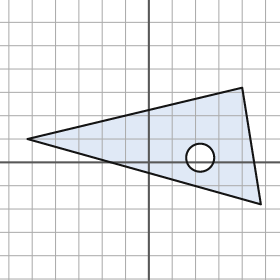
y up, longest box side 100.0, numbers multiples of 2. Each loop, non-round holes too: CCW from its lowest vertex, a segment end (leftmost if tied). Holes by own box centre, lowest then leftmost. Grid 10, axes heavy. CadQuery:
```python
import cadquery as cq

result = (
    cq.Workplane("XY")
    .moveTo(48.0, -18.0)
    .lineTo(40.0, 32.0)
    .lineTo(-52.0, 10.0)
    .close()
    .moveTo(22.0, 2.0)
    .circle(6.0)
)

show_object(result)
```